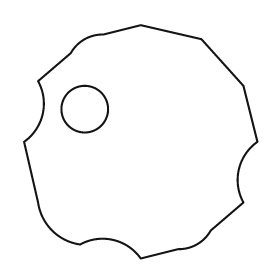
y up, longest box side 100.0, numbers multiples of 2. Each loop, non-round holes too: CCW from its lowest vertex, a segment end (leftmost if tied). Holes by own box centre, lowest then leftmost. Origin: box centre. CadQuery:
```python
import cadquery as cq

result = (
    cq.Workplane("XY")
    .moveTo(0.0, -50.0)
    .lineTo(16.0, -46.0)
    .threePointArc((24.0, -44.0), (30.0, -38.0))
    .lineTo(44.0, -26.0)
    .threePointArc((42.0, -12.0), (50.0, 0.0))
    .lineTo(44.0, 24.0)
    .lineTo(26.0, 44.0)
    .lineTo(0.0, 50.0)
    .lineTo(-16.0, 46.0)
    .threePointArc((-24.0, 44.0), (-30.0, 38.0))
    .lineTo(-44.0, 26.0)
    .threePointArc((-42.0, 12.0), (-50.0, 0.0))
    .lineTo(-44.0, -26.0)
    .threePointArc((-38.0, -38.0), (-26.0, -44.0))
    .threePointArc((-12.0, -42.0), (0.0, -50.0))
    .close()
    .moveTo(-24.0, 14.0)
    .circle(10.0)
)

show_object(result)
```